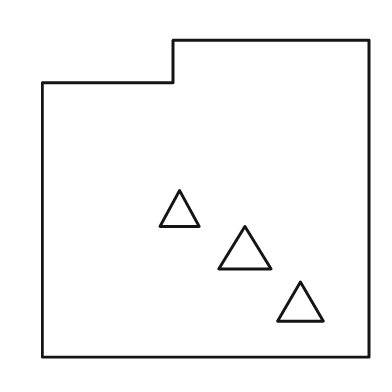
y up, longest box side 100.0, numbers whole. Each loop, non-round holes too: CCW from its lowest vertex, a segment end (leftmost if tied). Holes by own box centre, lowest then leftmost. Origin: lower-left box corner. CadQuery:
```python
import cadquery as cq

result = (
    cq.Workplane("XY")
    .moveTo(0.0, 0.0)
    .lineTo(100.0, 0.0)
    .lineTo(100.0, 97.0)
    .lineTo(40.0, 97.0)
    .lineTo(40.0, 84.0)
    .lineTo(0.0, 84.0)
    .close()
    .moveTo(72.0, 11.0)
    .lineTo(86.0, 11.0)
    .lineTo(79.0, 23.0)
    .close()
    .moveTo(54.0, 27.0)
    .lineTo(70.0, 27.0)
    .lineTo(62.0, 40.0)
    .close()
    .moveTo(36.0, 40.0)
    .lineTo(48.0, 40.0)
    .lineTo(42.0, 51.0)
    .close()
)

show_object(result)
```